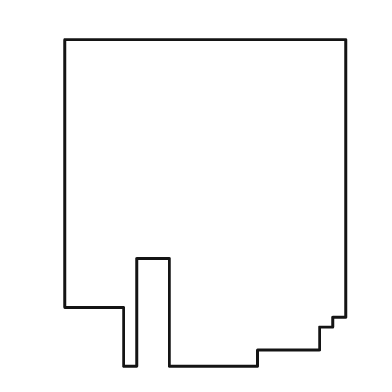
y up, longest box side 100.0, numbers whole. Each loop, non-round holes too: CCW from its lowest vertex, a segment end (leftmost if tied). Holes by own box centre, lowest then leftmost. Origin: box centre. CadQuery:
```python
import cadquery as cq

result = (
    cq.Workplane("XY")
    .moveTo(-25.0, -50.0)
    .lineTo(-21.0, -50.0)
    .lineTo(-21.0, -17.0)
    .lineTo(-11.0, -17.0)
    .lineTo(-11.0, -50.0)
    .lineTo(16.0, -50.0)
    .lineTo(16.0, -45.0)
    .lineTo(35.0, -45.0)
    .lineTo(35.0, -38.0)
    .lineTo(39.0, -38.0)
    .lineTo(39.0, -35.0)
    .lineTo(43.0, -35.0)
    .lineTo(43.0, 50.0)
    .lineTo(-43.0, 50.0)
    .lineTo(-43.0, -32.0)
    .lineTo(-25.0, -32.0)
    .close()
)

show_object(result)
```